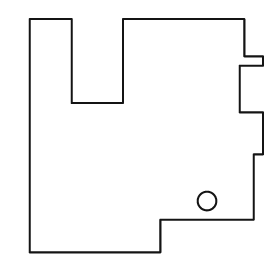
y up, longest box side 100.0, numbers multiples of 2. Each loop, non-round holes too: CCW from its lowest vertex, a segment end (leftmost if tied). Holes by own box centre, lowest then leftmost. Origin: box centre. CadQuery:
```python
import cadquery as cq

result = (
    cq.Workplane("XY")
    .moveTo(-50.0, -50.0)
    .lineTo(6.0, -50.0)
    .lineTo(6.0, -36.0)
    .lineTo(46.0, -36.0)
    .lineTo(46.0, -8.0)
    .lineTo(50.0, -8.0)
    .lineTo(50.0, 10.0)
    .lineTo(40.0, 10.0)
    .lineTo(40.0, 30.0)
    .lineTo(50.0, 30.0)
    .lineTo(50.0, 34.0)
    .lineTo(42.0, 34.0)
    .lineTo(42.0, 50.0)
    .lineTo(-10.0, 50.0)
    .lineTo(-10.0, 14.0)
    .lineTo(-32.0, 14.0)
    .lineTo(-32.0, 50.0)
    .lineTo(-50.0, 50.0)
    .close()
    .moveTo(26.0, -28.0)
    .circle(4.0)
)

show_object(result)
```